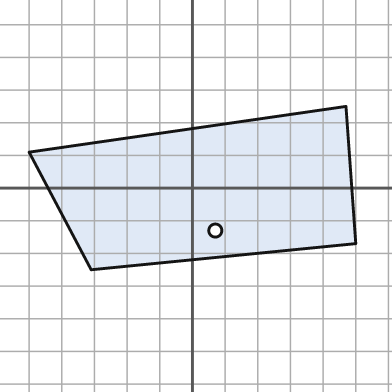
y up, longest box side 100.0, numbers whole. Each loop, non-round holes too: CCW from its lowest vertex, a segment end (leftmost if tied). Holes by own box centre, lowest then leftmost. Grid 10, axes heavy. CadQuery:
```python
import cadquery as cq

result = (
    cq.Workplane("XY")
    .moveTo(-31.0, -25.0)
    .lineTo(50.0, -17.0)
    .lineTo(47.0, 25.0)
    .lineTo(-50.0, 11.0)
    .close()
    .moveTo(7.0, -13.0)
    .circle(2.0)
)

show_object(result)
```